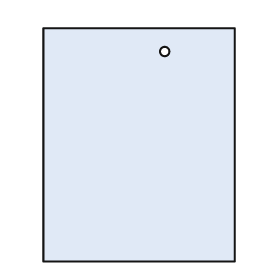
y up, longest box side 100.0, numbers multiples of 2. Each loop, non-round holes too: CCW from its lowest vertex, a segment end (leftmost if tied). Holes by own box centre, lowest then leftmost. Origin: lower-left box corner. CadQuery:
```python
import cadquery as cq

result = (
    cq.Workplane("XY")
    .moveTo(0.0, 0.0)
    .lineTo(82.0, 0.0)
    .lineTo(82.0, 100.0)
    .lineTo(0.0, 100.0)
    .close()
    .moveTo(52.0, 90.0)
    .circle(2.0)
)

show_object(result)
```